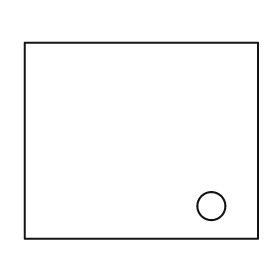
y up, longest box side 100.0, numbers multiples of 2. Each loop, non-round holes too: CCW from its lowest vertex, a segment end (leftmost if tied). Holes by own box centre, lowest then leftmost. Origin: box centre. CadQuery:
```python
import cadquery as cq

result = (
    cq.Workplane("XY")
    .moveTo(-50.0, -42.0)
    .lineTo(50.0, -42.0)
    .lineTo(50.0, 42.0)
    .lineTo(-50.0, 42.0)
    .close()
    .moveTo(30.0, -28.0)
    .circle(6.0)
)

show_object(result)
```